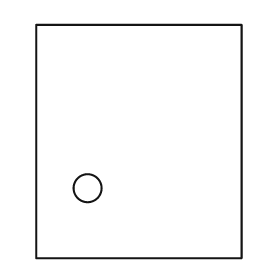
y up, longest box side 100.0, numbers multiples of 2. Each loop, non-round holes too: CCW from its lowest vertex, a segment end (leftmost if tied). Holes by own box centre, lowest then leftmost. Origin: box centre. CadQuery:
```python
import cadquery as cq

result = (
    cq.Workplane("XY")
    .moveTo(-44.0, -50.0)
    .lineTo(44.0, -50.0)
    .lineTo(44.0, 50.0)
    .lineTo(-44.0, 50.0)
    .close()
    .moveTo(-22.0, -20.0)
    .circle(6.0)
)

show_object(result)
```